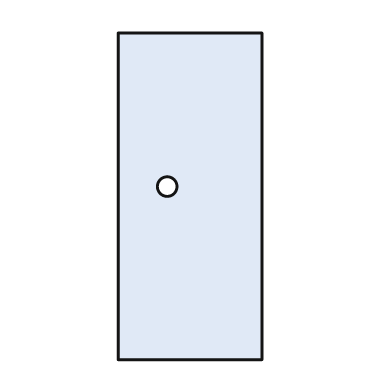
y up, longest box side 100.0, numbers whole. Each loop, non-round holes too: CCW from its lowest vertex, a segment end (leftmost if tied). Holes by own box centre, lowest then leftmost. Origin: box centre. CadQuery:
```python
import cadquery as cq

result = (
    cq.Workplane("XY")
    .moveTo(-22.0, -50.0)
    .lineTo(22.0, -50.0)
    .lineTo(22.0, 50.0)
    .lineTo(-22.0, 50.0)
    .close()
    .moveTo(-7.0, 3.0)
    .circle(3.0)
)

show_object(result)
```